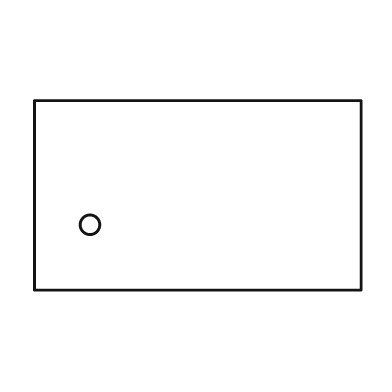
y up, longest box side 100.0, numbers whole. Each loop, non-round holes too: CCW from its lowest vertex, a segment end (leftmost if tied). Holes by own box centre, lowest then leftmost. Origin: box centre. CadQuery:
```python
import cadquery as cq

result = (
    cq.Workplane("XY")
    .moveTo(-50.0, -29.0)
    .lineTo(50.0, -29.0)
    .lineTo(50.0, 29.0)
    .lineTo(-50.0, 29.0)
    .close()
    .moveTo(-33.0, -9.0)
    .circle(3.0)
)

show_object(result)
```